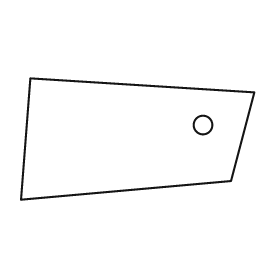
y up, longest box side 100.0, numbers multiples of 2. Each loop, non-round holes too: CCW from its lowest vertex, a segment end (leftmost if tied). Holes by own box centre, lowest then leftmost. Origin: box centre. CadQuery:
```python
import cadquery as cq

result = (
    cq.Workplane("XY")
    .moveTo(-50.0, -26.0)
    .lineTo(40.0, -18.0)
    .lineTo(50.0, 20.0)
    .lineTo(-46.0, 26.0)
    .close()
    .moveTo(28.0, 6.0)
    .circle(4.0)
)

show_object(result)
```